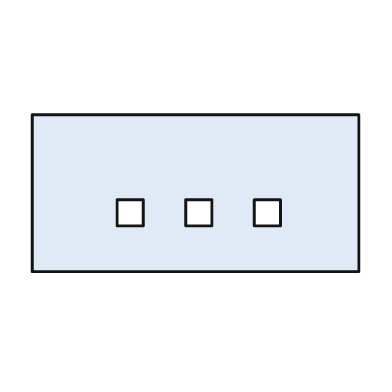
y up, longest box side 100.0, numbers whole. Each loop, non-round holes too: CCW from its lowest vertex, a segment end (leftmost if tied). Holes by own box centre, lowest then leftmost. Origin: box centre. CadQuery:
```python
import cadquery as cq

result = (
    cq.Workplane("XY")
    .moveTo(-50.0, -24.0)
    .lineTo(50.0, -24.0)
    .lineTo(50.0, 24.0)
    .lineTo(-50.0, 24.0)
    .close()
    .moveTo(-24.0, -10.0)
    .lineTo(-16.0, -10.0)
    .lineTo(-16.0, -2.0)
    .lineTo(-24.0, -2.0)
    .close()
    .moveTo(-3.0, -10.0)
    .lineTo(5.0, -10.0)
    .lineTo(5.0, -2.0)
    .lineTo(-3.0, -2.0)
    .close()
    .moveTo(18.0, -10.0)
    .lineTo(26.0, -10.0)
    .lineTo(26.0, -2.0)
    .lineTo(18.0, -2.0)
    .close()
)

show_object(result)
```